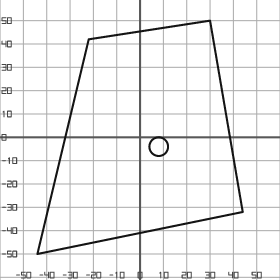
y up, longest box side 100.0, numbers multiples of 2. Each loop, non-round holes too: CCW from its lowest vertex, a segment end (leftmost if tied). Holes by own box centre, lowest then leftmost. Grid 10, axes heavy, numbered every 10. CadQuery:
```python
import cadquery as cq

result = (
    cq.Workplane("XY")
    .moveTo(-44.0, -50.0)
    .lineTo(44.0, -32.0)
    .lineTo(30.0, 50.0)
    .lineTo(-22.0, 42.0)
    .close()
    .moveTo(8.0, -4.0)
    .circle(4.0)
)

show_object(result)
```